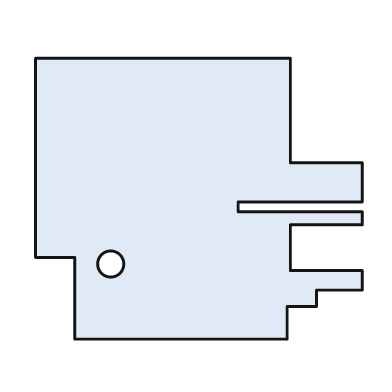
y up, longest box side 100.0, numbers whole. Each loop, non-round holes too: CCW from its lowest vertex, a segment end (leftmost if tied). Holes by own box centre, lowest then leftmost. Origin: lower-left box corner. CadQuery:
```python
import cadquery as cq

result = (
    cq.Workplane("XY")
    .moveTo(12.0, 0.0)
    .lineTo(77.0, 0.0)
    .lineTo(77.0, 10.0)
    .lineTo(86.0, 10.0)
    .lineTo(86.0, 15.0)
    .lineTo(100.0, 15.0)
    .lineTo(100.0, 21.0)
    .lineTo(78.0, 21.0)
    .lineTo(78.0, 35.0)
    .lineTo(100.0, 35.0)
    .lineTo(100.0, 39.0)
    .lineTo(62.0, 39.0)
    .lineTo(62.0, 42.0)
    .lineTo(100.0, 42.0)
    .lineTo(100.0, 54.0)
    .lineTo(78.0, 54.0)
    .lineTo(78.0, 86.0)
    .lineTo(0.0, 86.0)
    .lineTo(0.0, 25.0)
    .lineTo(12.0, 25.0)
    .close()
    .moveTo(23.0, 23.0)
    .circle(4.0)
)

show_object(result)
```